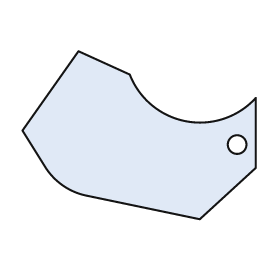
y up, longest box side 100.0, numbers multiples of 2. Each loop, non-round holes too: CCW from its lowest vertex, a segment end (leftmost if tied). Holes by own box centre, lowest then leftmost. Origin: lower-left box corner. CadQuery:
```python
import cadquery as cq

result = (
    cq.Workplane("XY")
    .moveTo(76.0, 0.0)
    .lineTo(100.0, 22.0)
    .lineTo(100.0, 52.0)
    .threePointArc((70.0, 42.0), (46.0, 62.0))
    .lineTo(24.0, 72.0)
    .lineTo(0.0, 38.0)
    .lineTo(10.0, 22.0)
    .threePointArc((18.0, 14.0), (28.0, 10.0))
    .close()
    .moveTo(92.0, 32.0)
    .circle(4.0)
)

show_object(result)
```